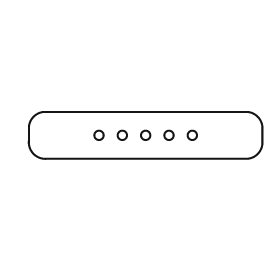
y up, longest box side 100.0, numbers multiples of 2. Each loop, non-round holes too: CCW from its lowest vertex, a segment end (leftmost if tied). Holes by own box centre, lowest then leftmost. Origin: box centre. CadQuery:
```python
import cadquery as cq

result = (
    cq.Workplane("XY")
    .moveTo(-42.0, -10.0)
    .lineTo(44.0, -10.0)
    .threePointArc((48.0, -8.0), (50.0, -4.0))
    .lineTo(50.0, 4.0)
    .threePointArc((48.0, 8.0), (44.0, 10.0))
    .lineTo(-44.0, 10.0)
    .threePointArc((-48.0, 8.0), (-50.0, 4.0))
    .lineTo(-50.0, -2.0)
    .threePointArc((-48.0, -8.0), (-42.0, -10.0))
    .close()
    .moveTo(-20.0, 0.0)
    .circle(2.0)
    .moveTo(-10.0, 0.0)
    .circle(2.0)
    .moveTo(0.0, 0.0)
    .circle(2.0)
    .moveTo(10.0, 0.0)
    .circle(2.0)
    .moveTo(20.0, 0.0)
    .circle(2.0)
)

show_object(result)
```